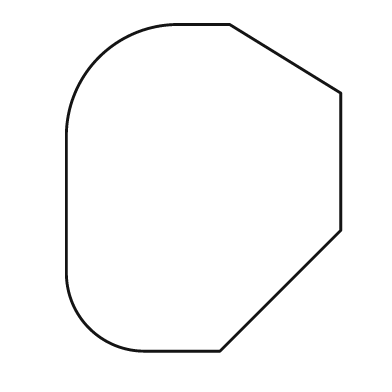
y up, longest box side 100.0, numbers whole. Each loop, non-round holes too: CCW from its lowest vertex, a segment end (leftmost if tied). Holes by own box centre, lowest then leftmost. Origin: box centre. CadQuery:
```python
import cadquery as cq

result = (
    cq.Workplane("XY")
    .moveTo(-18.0, -50.0)
    .lineTo(5.0, -50.0)
    .lineTo(42.0, -13.0)
    .lineTo(42.0, 29.0)
    .lineTo(8.0, 50.0)
    .lineTo(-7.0, 50.0)
    .threePointArc((-32.0, 40.0), (-42.0, 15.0))
    .lineTo(-42.0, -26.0)
    .threePointArc((-35.0, -43.0), (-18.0, -50.0))
    .close()
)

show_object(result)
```